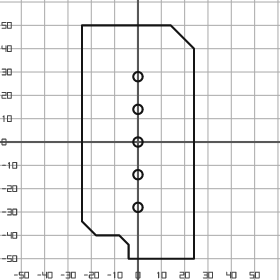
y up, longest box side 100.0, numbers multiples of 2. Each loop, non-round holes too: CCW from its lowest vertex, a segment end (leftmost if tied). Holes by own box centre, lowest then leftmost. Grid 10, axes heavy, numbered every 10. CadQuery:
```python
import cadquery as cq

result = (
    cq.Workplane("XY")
    .moveTo(-4.0, -50.0)
    .lineTo(24.0, -50.0)
    .lineTo(24.0, 40.0)
    .lineTo(14.0, 50.0)
    .lineTo(-24.0, 50.0)
    .lineTo(-24.0, -34.0)
    .lineTo(-18.0, -40.0)
    .lineTo(-8.0, -40.0)
    .lineTo(-4.0, -44.0)
    .close()
    .moveTo(0.0, -28.0)
    .circle(2.0)
    .moveTo(0.0, -14.0)
    .circle(2.0)
    .moveTo(0.0, 0.0)
    .circle(2.0)
    .moveTo(0.0, 14.0)
    .circle(2.0)
    .moveTo(0.0, 28.0)
    .circle(2.0)
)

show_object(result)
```